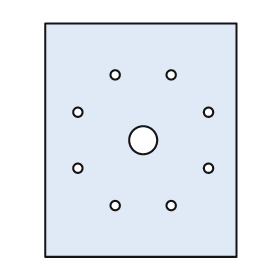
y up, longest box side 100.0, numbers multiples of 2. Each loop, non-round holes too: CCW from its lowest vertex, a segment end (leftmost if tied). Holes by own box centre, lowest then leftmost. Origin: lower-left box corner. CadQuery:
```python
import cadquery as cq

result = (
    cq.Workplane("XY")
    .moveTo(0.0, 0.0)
    .lineTo(82.0, 0.0)
    .lineTo(82.0, 100.0)
    .lineTo(0.0, 100.0)
    .close()
    .moveTo(30.0, 22.0)
    .circle(2.0)
    .moveTo(54.0, 22.0)
    .circle(2.0)
    .moveTo(14.0, 38.0)
    .circle(2.0)
    .moveTo(70.0, 38.0)
    .circle(2.0)
    .moveTo(42.0, 50.0)
    .circle(6.0)
    .moveTo(14.0, 62.0)
    .circle(2.0)
    .moveTo(70.0, 62.0)
    .circle(2.0)
    .moveTo(30.0, 78.0)
    .circle(2.0)
    .moveTo(54.0, 78.0)
    .circle(2.0)
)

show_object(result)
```